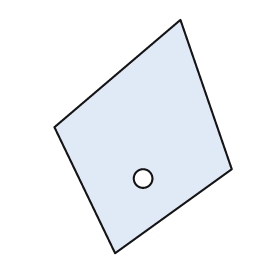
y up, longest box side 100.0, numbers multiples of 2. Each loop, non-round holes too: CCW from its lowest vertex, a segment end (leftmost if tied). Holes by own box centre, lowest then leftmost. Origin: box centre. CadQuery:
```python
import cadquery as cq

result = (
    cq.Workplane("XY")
    .moveTo(-12.0, -50.0)
    .lineTo(38.0, -14.0)
    .lineTo(16.0, 50.0)
    .lineTo(-38.0, 4.0)
    .close()
    .moveTo(0.0, -18.0)
    .circle(4.0)
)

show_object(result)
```